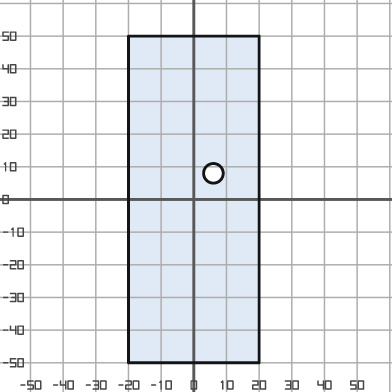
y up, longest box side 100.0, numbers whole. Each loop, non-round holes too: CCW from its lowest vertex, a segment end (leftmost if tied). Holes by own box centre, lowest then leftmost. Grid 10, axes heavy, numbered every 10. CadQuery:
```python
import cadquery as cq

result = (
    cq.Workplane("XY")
    .moveTo(-20.0, -50.0)
    .lineTo(20.0, -50.0)
    .lineTo(20.0, 50.0)
    .lineTo(-20.0, 50.0)
    .close()
    .moveTo(6.0, 8.0)
    .circle(3.0)
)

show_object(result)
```